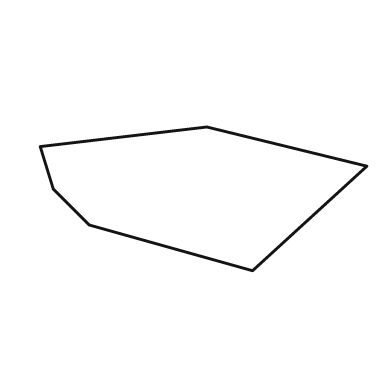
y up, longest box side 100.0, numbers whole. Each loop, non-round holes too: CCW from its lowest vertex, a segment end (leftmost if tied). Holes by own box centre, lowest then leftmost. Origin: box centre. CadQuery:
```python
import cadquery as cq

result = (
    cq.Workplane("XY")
    .moveTo(15.0, -22.0)
    .lineTo(50.0, 10.0)
    .lineTo(1.0, 22.0)
    .lineTo(-50.0, 16.0)
    .lineTo(-46.0, 3.0)
    .lineTo(-35.0, -8.0)
    .close()
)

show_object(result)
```